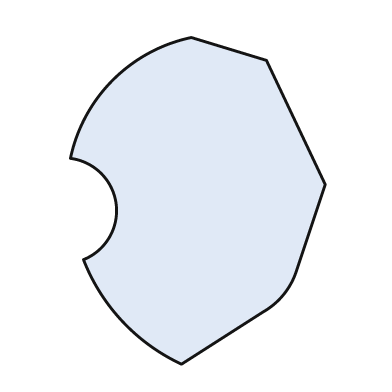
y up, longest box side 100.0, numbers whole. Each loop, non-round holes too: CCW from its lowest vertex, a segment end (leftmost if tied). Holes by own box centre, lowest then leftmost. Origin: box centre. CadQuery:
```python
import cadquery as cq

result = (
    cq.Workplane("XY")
    .moveTo(-5.0, -50.0)
    .lineTo(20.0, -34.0)
    .threePointArc((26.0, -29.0), (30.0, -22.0))
    .lineTo(39.0, 5.0)
    .lineTo(21.0, 43.0)
    .lineTo(-2.0, 50.0)
    .threePointArc((-26.0, 37.0), (-39.0, 13.0))
    .threePointArc((-25.0, -1.0), (-35.0, -18.0))
    .threePointArc((-23.0, -37.0), (-5.0, -50.0))
    .close()
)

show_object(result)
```